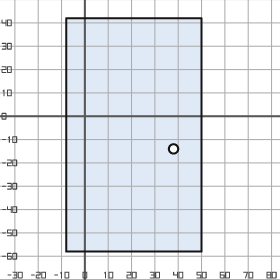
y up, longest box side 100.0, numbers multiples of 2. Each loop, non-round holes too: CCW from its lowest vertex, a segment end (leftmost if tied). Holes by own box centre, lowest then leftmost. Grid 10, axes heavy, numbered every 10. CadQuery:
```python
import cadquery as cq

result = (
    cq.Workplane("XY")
    .moveTo(-8.0, -58.0)
    .lineTo(50.0, -58.0)
    .lineTo(50.0, 42.0)
    .lineTo(-8.0, 42.0)
    .close()
    .moveTo(38.0, -14.0)
    .circle(2.0)
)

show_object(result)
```